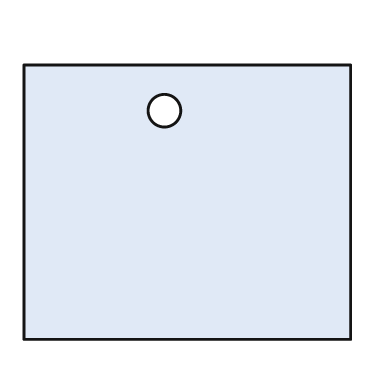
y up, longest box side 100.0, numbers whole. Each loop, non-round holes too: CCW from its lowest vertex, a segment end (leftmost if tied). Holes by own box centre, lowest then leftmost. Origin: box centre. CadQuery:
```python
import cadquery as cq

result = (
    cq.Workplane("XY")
    .moveTo(-50.0, -42.0)
    .lineTo(50.0, -42.0)
    .lineTo(50.0, 42.0)
    .lineTo(-50.0, 42.0)
    .close()
    .moveTo(-7.0, 28.0)
    .circle(5.0)
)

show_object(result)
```